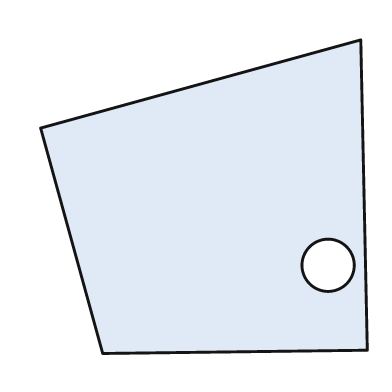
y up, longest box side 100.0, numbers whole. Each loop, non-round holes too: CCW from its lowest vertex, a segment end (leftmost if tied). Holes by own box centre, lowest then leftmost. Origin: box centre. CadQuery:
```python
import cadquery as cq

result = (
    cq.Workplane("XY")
    .moveTo(-31.0, -48.0)
    .lineTo(50.0, -47.0)
    .lineTo(48.0, 48.0)
    .lineTo(-50.0, 21.0)
    .close()
    .moveTo(38.0, -21.0)
    .circle(8.0)
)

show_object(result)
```